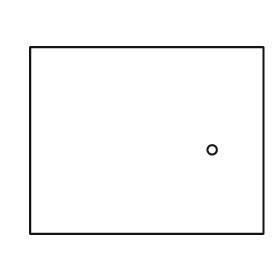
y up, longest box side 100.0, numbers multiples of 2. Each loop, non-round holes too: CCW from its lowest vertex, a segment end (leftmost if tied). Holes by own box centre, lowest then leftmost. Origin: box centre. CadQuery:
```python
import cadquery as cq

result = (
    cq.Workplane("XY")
    .moveTo(-50.0, -40.0)
    .lineTo(50.0, -40.0)
    .lineTo(50.0, 40.0)
    .lineTo(-50.0, 40.0)
    .close()
    .moveTo(28.0, -4.0)
    .circle(2.0)
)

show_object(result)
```